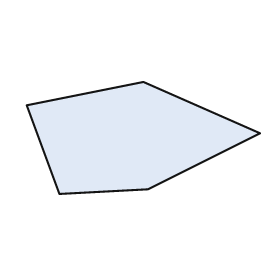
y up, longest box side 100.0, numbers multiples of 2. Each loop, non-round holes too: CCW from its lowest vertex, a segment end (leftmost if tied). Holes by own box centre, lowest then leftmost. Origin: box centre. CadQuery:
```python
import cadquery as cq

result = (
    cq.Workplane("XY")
    .moveTo(-36.0, -24.0)
    .lineTo(2.0, -22.0)
    .lineTo(50.0, 2.0)
    .lineTo(0.0, 24.0)
    .lineTo(-50.0, 14.0)
    .close()
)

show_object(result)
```